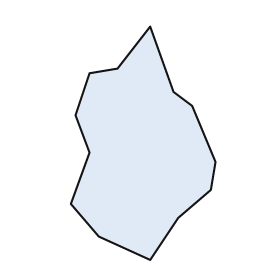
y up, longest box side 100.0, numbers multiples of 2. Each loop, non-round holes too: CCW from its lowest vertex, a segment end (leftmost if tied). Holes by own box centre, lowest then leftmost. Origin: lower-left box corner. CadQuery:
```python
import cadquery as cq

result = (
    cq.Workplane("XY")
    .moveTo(34.0, 0.0)
    .lineTo(46.0, 18.0)
    .lineTo(60.0, 30.0)
    .lineTo(62.0, 42.0)
    .lineTo(52.0, 66.0)
    .lineTo(44.0, 72.0)
    .lineTo(34.0, 100.0)
    .lineTo(20.0, 82.0)
    .lineTo(8.0, 80.0)
    .lineTo(2.0, 62.0)
    .lineTo(8.0, 46.0)
    .lineTo(0.0, 24.0)
    .lineTo(12.0, 10.0)
    .close()
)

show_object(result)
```